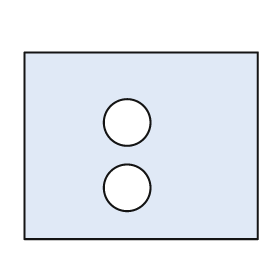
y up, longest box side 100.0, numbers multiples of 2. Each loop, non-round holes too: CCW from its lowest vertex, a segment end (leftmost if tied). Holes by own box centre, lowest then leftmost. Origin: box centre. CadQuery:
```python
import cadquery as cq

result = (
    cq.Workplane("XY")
    .moveTo(-50.0, -40.0)
    .lineTo(50.0, -40.0)
    .lineTo(50.0, 40.0)
    .lineTo(-50.0, 40.0)
    .close()
    .moveTo(-6.0, -18.0)
    .circle(10.0)
    .moveTo(-6.0, 10.0)
    .circle(10.0)
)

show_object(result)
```